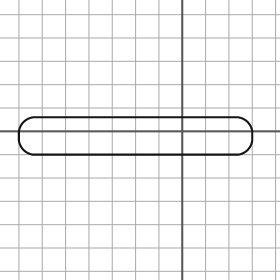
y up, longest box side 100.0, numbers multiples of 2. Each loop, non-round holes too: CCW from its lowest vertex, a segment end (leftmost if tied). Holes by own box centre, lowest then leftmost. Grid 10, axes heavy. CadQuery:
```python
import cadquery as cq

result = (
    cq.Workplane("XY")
    .moveTo(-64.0, -10.0)
    .lineTo(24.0, -10.0)
    .threePointArc((28.0, -8.0), (30.0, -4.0))
    .lineTo(30.0, 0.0)
    .threePointArc((28.0, 4.0), (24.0, 6.0))
    .lineTo(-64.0, 6.0)
    .threePointArc((-68.0, 4.0), (-70.0, 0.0))
    .lineTo(-70.0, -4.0)
    .threePointArc((-68.0, -8.0), (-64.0, -10.0))
    .close()
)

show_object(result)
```